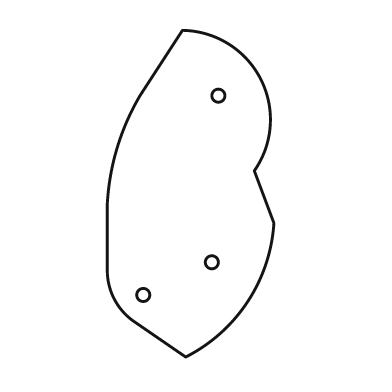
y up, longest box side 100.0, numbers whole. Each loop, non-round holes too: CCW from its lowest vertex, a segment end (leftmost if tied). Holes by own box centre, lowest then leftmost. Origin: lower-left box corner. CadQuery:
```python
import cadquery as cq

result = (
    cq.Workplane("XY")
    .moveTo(24.0, 0.0)
    .threePointArc((43.0, 17.0), (51.0, 41.0))
    .lineTo(45.0, 57.0)
    .threePointArc((47.0, 85.0), (23.0, 100.0))
    .lineTo(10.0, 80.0)
    .threePointArc((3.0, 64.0), (0.0, 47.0))
    .lineTo(0.0, 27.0)
    .threePointArc((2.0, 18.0), (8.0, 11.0))
    .close()
    .moveTo(11.0, 19.0)
    .circle(2.0)
    .moveTo(32.0, 29.0)
    .circle(2.0)
    .moveTo(34.0, 80.0)
    .circle(2.0)
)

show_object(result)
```